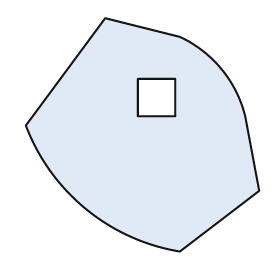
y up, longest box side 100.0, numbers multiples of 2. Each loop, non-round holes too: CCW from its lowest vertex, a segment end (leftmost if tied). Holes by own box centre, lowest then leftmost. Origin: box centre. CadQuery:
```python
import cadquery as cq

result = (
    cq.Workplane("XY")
    .moveTo(16.0, -50.0)
    .lineTo(50.0, -24.0)
    .lineTo(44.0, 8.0)
    .threePointArc((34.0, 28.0), (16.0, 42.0))
    .lineTo(-16.0, 50.0)
    .lineTo(-50.0, 4.0)
    .threePointArc((-24.0, -32.0), (16.0, -50.0))
    .close()
    .moveTo(-2.0, 8.0)
    .lineTo(14.0, 8.0)
    .lineTo(14.0, 24.0)
    .lineTo(-2.0, 24.0)
    .close()
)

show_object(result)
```